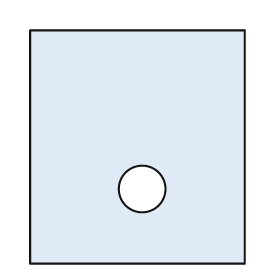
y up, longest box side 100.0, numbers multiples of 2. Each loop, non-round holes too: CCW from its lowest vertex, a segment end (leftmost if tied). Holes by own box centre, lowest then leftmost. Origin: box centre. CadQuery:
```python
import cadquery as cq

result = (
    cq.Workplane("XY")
    .moveTo(-46.0, -50.0)
    .lineTo(46.0, -50.0)
    .lineTo(46.0, 50.0)
    .lineTo(-46.0, 50.0)
    .close()
    .moveTo(2.0, -18.0)
    .circle(10.0)
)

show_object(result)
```